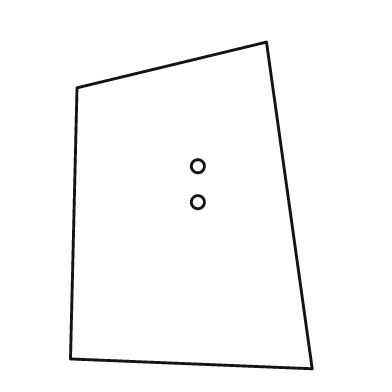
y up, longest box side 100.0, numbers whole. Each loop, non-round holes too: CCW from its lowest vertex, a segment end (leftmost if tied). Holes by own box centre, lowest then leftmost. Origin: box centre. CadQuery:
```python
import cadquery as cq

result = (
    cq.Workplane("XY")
    .moveTo(37.0, -50.0)
    .lineTo(23.0, 50.0)
    .lineTo(-35.0, 36.0)
    .lineTo(-37.0, -47.0)
    .close()
    .moveTo(2.0, 1.0)
    .circle(2.0)
    .moveTo(2.0, 12.0)
    .circle(2.0)
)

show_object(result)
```